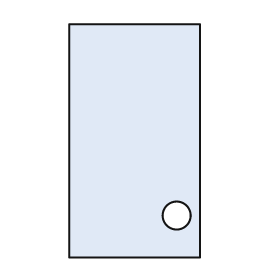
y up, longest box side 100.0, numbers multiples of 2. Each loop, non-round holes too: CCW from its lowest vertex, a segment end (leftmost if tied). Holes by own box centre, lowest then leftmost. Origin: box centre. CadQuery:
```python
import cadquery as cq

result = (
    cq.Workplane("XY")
    .moveTo(-28.0, -50.0)
    .lineTo(28.0, -50.0)
    .lineTo(28.0, 50.0)
    .lineTo(-28.0, 50.0)
    .close()
    .moveTo(18.0, -32.0)
    .circle(6.0)
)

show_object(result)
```